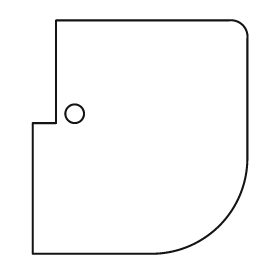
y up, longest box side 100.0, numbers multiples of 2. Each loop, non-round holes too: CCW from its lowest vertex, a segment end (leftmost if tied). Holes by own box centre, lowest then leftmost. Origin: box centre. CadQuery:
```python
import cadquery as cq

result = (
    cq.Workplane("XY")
    .moveTo(-46.0, -50.0)
    .lineTo(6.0, -50.0)
    .threePointArc((34.0, -38.0), (46.0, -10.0))
    .lineTo(46.0, 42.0)
    .threePointArc((44.0, 48.0), (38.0, 50.0))
    .lineTo(-36.0, 50.0)
    .lineTo(-36.0, 6.0)
    .lineTo(-46.0, 6.0)
    .close()
    .moveTo(-28.0, 10.0)
    .circle(4.0)
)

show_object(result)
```